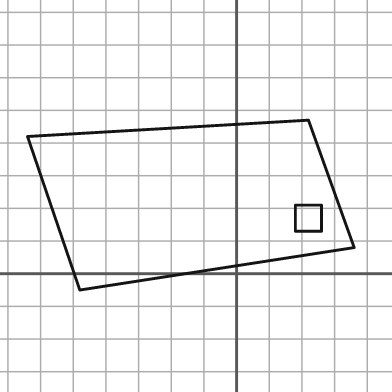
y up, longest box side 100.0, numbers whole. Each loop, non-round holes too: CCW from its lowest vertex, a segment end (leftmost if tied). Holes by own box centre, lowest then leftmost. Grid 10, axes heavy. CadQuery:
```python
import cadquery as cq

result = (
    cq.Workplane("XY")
    .moveTo(-48.0, -5.0)
    .lineTo(36.0, 8.0)
    .lineTo(22.0, 47.0)
    .lineTo(-64.0, 42.0)
    .close()
    .moveTo(18.0, 13.0)
    .lineTo(26.0, 13.0)
    .lineTo(26.0, 21.0)
    .lineTo(18.0, 21.0)
    .close()
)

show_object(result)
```